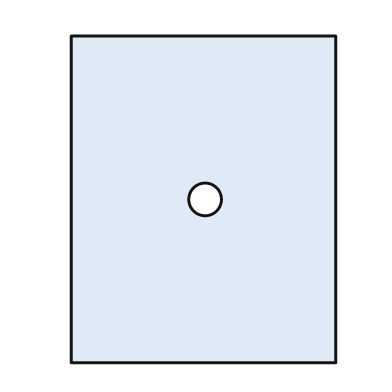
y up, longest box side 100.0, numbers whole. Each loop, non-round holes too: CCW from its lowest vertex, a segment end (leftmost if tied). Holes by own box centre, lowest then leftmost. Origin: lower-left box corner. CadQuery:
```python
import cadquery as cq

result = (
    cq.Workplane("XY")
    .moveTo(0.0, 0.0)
    .lineTo(81.0, 0.0)
    .lineTo(81.0, 100.0)
    .lineTo(0.0, 100.0)
    .close()
    .moveTo(41.0, 50.0)
    .circle(5.0)
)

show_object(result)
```